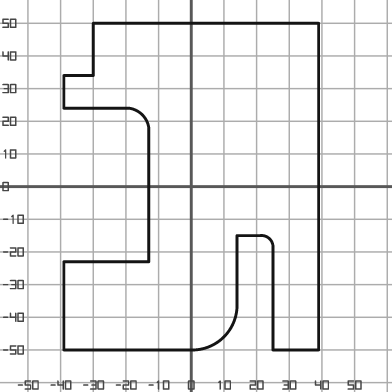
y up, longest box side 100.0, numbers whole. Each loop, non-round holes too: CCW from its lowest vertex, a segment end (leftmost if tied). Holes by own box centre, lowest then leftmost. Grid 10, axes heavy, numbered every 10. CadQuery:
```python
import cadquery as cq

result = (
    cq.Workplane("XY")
    .moveTo(-39.0, -50.0)
    .lineTo(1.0, -50.0)
    .threePointArc((10.0, -46.0), (14.0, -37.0))
    .lineTo(14.0, -15.0)
    .lineTo(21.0, -15.0)
    .threePointArc((24.0, -16.0), (25.0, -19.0))
    .lineTo(25.0, -50.0)
    .lineTo(39.0, -50.0)
    .lineTo(39.0, 50.0)
    .lineTo(-30.0, 50.0)
    .lineTo(-30.0, 34.0)
    .lineTo(-39.0, 34.0)
    .lineTo(-39.0, 24.0)
    .lineTo(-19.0, 24.0)
    .threePointArc((-15.0, 22.0), (-13.0, 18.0))
    .lineTo(-13.0, -23.0)
    .lineTo(-39.0, -23.0)
    .close()
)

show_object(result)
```